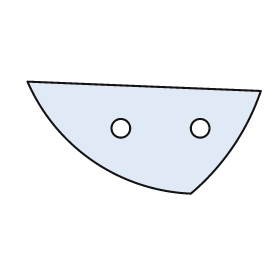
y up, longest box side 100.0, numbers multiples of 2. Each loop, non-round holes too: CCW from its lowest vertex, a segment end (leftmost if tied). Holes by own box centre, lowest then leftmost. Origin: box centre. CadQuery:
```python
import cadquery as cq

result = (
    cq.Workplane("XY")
    .moveTo(20.0, -24.0)
    .threePointArc((38.0, -4.0), (50.0, 20.0))
    .lineTo(-50.0, 24.0)
    .threePointArc((-22.0, -10.0), (20.0, -24.0))
    .close()
    .moveTo(-10.0, 4.0)
    .circle(4.0)
    .moveTo(24.0, 4.0)
    .circle(4.0)
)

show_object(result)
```